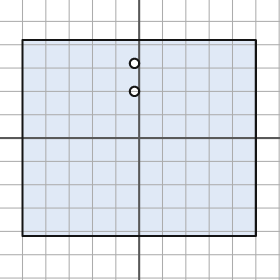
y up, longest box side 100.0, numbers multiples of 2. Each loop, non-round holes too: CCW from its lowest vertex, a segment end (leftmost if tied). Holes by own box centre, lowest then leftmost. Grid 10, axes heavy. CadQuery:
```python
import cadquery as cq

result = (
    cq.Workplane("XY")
    .moveTo(-50.0, -42.0)
    .lineTo(50.0, -42.0)
    .lineTo(50.0, 42.0)
    .lineTo(-50.0, 42.0)
    .close()
    .moveTo(-2.0, 20.0)
    .circle(2.0)
    .moveTo(-2.0, 32.0)
    .circle(2.0)
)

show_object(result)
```